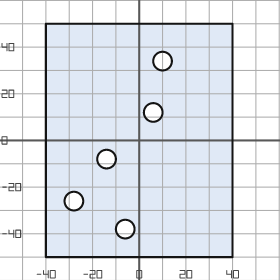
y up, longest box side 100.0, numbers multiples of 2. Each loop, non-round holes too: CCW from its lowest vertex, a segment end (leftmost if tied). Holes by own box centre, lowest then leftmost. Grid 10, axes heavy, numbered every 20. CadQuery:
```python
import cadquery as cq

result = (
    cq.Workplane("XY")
    .moveTo(-40.0, -50.0)
    .lineTo(40.0, -50.0)
    .lineTo(40.0, 50.0)
    .lineTo(-40.0, 50.0)
    .close()
    .moveTo(-6.0, -38.0)
    .circle(4.0)
    .moveTo(-28.0, -26.0)
    .circle(4.0)
    .moveTo(-14.0, -8.0)
    .circle(4.0)
    .moveTo(6.0, 12.0)
    .circle(4.0)
    .moveTo(10.0, 34.0)
    .circle(4.0)
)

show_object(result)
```